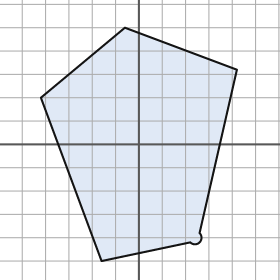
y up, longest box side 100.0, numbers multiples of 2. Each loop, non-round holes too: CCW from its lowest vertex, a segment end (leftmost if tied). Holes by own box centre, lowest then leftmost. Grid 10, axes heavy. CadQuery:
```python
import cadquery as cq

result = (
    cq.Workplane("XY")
    .moveTo(-16.0, -50.0)
    .lineTo(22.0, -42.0)
    .threePointArc((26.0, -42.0), (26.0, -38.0))
    .lineTo(42.0, 32.0)
    .lineTo(-6.0, 50.0)
    .lineTo(-42.0, 20.0)
    .close()
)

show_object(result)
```